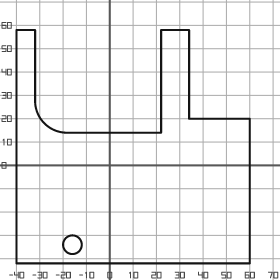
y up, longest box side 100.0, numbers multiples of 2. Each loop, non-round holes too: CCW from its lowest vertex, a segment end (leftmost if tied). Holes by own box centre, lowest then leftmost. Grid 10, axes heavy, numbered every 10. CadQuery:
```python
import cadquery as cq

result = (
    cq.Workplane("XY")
    .moveTo(-40.0, -42.0)
    .lineTo(60.0, -42.0)
    .lineTo(60.0, 20.0)
    .lineTo(34.0, 20.0)
    .lineTo(34.0, 58.0)
    .lineTo(22.0, 58.0)
    .lineTo(22.0, 14.0)
    .lineTo(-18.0, 14.0)
    .threePointArc((-28.0, 18.0), (-32.0, 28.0))
    .lineTo(-32.0, 58.0)
    .lineTo(-40.0, 58.0)
    .close()
    .moveTo(-16.0, -34.0)
    .circle(4.0)
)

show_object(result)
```